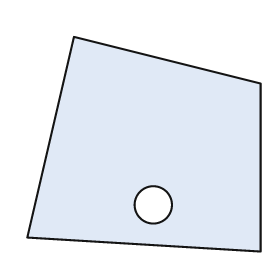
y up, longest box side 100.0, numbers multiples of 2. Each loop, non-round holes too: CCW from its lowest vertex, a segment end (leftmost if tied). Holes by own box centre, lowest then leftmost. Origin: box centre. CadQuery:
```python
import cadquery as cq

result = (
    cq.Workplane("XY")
    .moveTo(50.0, -46.0)
    .lineTo(50.0, 26.0)
    .lineTo(-30.0, 46.0)
    .lineTo(-50.0, -40.0)
    .close()
    .moveTo(4.0, -26.0)
    .circle(8.0)
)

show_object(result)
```